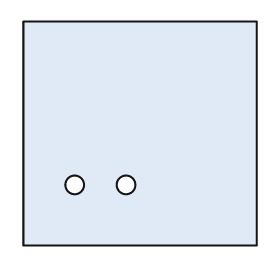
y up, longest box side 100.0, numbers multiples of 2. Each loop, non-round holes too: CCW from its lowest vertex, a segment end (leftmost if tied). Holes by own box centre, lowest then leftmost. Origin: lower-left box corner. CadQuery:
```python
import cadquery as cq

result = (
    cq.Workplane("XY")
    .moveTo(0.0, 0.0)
    .lineTo(100.0, 0.0)
    .lineTo(100.0, 96.0)
    .lineTo(0.0, 96.0)
    .close()
    .moveTo(22.0, 26.0)
    .circle(4.0)
    .moveTo(44.0, 26.0)
    .circle(4.0)
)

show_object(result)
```